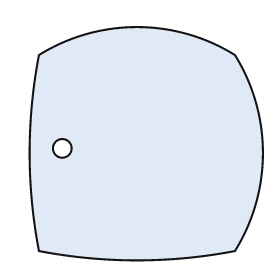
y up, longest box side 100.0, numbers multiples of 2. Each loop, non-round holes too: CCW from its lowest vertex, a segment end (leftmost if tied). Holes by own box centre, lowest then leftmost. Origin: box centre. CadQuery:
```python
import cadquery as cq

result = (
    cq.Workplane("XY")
    .moveTo(-46.0, -46.0)
    .threePointArc((-4.0, -50.0), (38.0, -46.0))
    .threePointArc((50.0, -4.0), (38.0, 38.0))
    .threePointArc((-4.0, 50.0), (-46.0, 38.0))
    .threePointArc((-50.0, -4.0), (-46.0, -46.0))
    .close()
    .moveTo(-36.0, -2.0)
    .circle(4.0)
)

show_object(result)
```